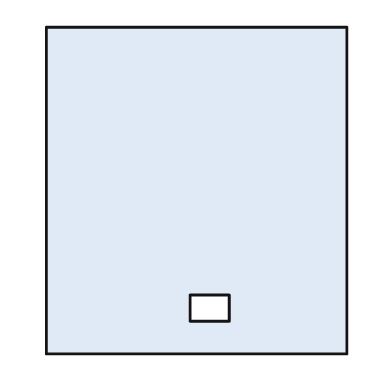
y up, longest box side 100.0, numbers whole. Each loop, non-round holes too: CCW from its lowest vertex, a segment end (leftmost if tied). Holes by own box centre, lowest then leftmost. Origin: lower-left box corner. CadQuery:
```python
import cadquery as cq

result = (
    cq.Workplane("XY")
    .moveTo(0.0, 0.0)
    .lineTo(92.0, 0.0)
    .lineTo(92.0, 100.0)
    .lineTo(0.0, 100.0)
    .close()
    .moveTo(44.0, 10.0)
    .lineTo(56.0, 10.0)
    .lineTo(56.0, 18.0)
    .lineTo(44.0, 18.0)
    .close()
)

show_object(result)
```